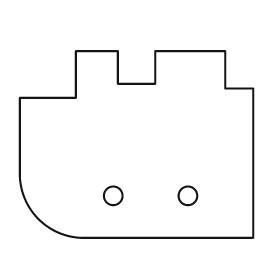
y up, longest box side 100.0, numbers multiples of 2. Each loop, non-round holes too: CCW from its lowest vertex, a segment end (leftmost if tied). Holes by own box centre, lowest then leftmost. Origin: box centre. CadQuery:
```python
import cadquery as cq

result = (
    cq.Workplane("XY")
    .moveTo(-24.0, -40.0)
    .lineTo(50.0, -40.0)
    .lineTo(50.0, 24.0)
    .lineTo(38.0, 24.0)
    .lineTo(38.0, 40.0)
    .lineTo(8.0, 40.0)
    .lineTo(8.0, 26.0)
    .lineTo(-8.0, 26.0)
    .lineTo(-8.0, 40.0)
    .lineTo(-26.0, 40.0)
    .lineTo(-26.0, 20.0)
    .lineTo(-50.0, 20.0)
    .lineTo(-50.0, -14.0)
    .threePointArc((-42.0, -32.0), (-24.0, -40.0))
    .close()
    .moveTo(-10.0, -22.0)
    .circle(4.0)
    .moveTo(22.0, -22.0)
    .circle(4.0)
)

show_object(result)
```